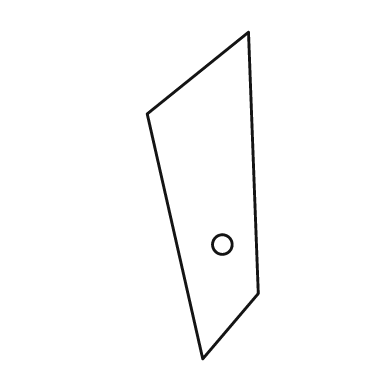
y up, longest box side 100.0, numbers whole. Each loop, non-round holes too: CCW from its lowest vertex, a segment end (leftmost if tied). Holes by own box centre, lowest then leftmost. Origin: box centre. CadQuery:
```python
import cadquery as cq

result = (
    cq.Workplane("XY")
    .moveTo(0.0, -50.0)
    .lineTo(17.0, -30.0)
    .lineTo(14.0, 50.0)
    .lineTo(-17.0, 25.0)
    .close()
    .moveTo(6.0, -15.0)
    .circle(3.0)
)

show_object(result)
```